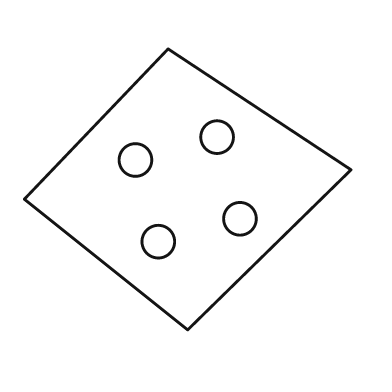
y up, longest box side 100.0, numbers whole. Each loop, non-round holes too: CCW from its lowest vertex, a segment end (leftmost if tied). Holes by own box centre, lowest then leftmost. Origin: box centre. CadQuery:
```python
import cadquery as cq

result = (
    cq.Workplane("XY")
    .moveTo(0.0, -43.0)
    .lineTo(50.0, 6.0)
    .lineTo(-6.0, 43.0)
    .lineTo(-50.0, -3.0)
    .close()
    .moveTo(-9.0, -16.0)
    .circle(5.0)
    .moveTo(16.0, -9.0)
    .circle(5.0)
    .moveTo(-16.0, 9.0)
    .circle(5.0)
    .moveTo(9.0, 16.0)
    .circle(5.0)
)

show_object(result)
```